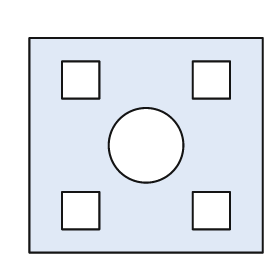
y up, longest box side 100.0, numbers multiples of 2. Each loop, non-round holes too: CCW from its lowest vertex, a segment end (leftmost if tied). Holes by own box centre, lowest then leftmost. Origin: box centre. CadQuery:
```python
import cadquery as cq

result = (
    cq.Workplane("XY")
    .moveTo(-50.0, -46.0)
    .lineTo(50.0, -46.0)
    .lineTo(50.0, 46.0)
    .lineTo(-50.0, 46.0)
    .close()
    .moveTo(-36.0, -36.0)
    .lineTo(-20.0, -36.0)
    .lineTo(-20.0, -20.0)
    .lineTo(-36.0, -20.0)
    .close()
    .moveTo(20.0, -36.0)
    .lineTo(36.0, -36.0)
    .lineTo(36.0, -20.0)
    .lineTo(20.0, -20.0)
    .close()
    .moveTo(0.0, 0.0)
    .circle(16.0)
    .moveTo(-36.0, 20.0)
    .lineTo(-20.0, 20.0)
    .lineTo(-20.0, 36.0)
    .lineTo(-36.0, 36.0)
    .close()
    .moveTo(20.0, 20.0)
    .lineTo(36.0, 20.0)
    .lineTo(36.0, 36.0)
    .lineTo(20.0, 36.0)
    .close()
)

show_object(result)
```